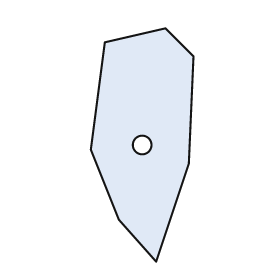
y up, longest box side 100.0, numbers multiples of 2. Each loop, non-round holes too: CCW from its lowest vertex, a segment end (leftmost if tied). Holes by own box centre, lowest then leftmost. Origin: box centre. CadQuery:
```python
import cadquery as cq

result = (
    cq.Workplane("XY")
    .moveTo(6.0, -50.0)
    .lineTo(20.0, -8.0)
    .lineTo(22.0, 38.0)
    .lineTo(10.0, 50.0)
    .lineTo(-16.0, 44.0)
    .lineTo(-22.0, -2.0)
    .lineTo(-10.0, -32.0)
    .close()
    .moveTo(0.0, 0.0)
    .circle(4.0)
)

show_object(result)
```